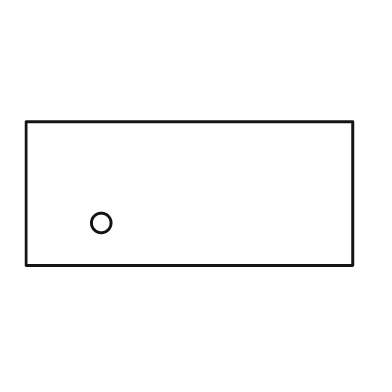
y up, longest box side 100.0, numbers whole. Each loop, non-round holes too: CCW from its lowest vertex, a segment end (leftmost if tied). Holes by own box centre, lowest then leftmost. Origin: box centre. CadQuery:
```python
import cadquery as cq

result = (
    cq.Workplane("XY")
    .moveTo(-50.0, -22.0)
    .lineTo(50.0, -22.0)
    .lineTo(50.0, 22.0)
    .lineTo(-50.0, 22.0)
    .close()
    .moveTo(-27.0, -9.0)
    .circle(3.0)
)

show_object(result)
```